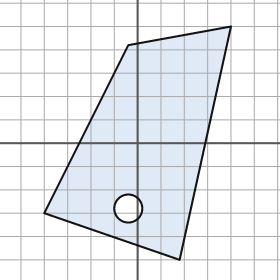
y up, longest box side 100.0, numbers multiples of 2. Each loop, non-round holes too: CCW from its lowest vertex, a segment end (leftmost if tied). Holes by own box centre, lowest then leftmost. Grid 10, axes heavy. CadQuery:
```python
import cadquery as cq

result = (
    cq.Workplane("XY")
    .moveTo(18.0, -50.0)
    .lineTo(40.0, 50.0)
    .lineTo(-4.0, 42.0)
    .lineTo(-40.0, -30.0)
    .close()
    .moveTo(-4.0, -28.0)
    .circle(6.0)
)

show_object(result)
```